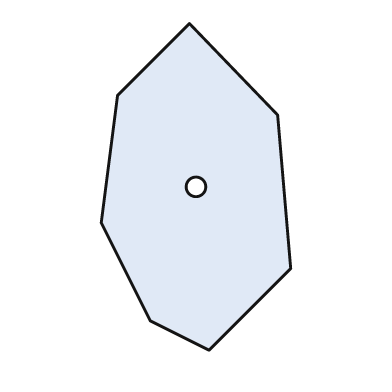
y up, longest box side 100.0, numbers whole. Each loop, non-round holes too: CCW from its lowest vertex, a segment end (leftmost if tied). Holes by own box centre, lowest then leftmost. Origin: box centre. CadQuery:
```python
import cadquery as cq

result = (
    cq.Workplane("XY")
    .moveTo(4.0, -50.0)
    .lineTo(29.0, -25.0)
    .lineTo(25.0, 22.0)
    .lineTo(-2.0, 50.0)
    .lineTo(-24.0, 28.0)
    .lineTo(-29.0, -11.0)
    .lineTo(-14.0, -41.0)
    .close()
    .moveTo(0.0, 0.0)
    .circle(3.0)
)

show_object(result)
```